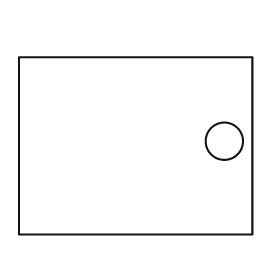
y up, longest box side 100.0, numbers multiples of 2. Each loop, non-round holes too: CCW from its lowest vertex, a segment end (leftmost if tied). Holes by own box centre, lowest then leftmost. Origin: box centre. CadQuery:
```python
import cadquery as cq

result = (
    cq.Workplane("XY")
    .moveTo(-50.0, -38.0)
    .lineTo(50.0, -38.0)
    .lineTo(50.0, 38.0)
    .lineTo(-50.0, 38.0)
    .close()
    .moveTo(38.0, 2.0)
    .circle(8.0)
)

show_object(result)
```